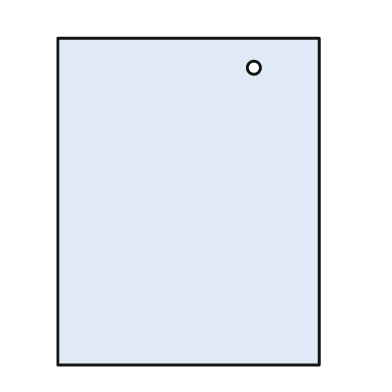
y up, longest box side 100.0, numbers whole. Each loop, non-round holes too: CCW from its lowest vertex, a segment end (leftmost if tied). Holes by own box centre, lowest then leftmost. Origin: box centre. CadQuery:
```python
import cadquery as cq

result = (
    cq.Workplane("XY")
    .moveTo(-40.0, -50.0)
    .lineTo(40.0, -50.0)
    .lineTo(40.0, 50.0)
    .lineTo(-40.0, 50.0)
    .close()
    .moveTo(20.0, 41.0)
    .circle(2.0)
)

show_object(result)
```